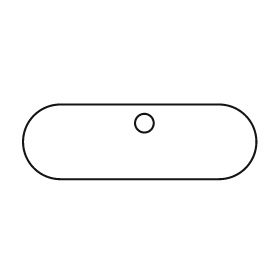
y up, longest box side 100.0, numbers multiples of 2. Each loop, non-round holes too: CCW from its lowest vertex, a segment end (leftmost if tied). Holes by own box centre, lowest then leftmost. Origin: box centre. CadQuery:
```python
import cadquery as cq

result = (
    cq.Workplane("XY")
    .moveTo(-34.0, -16.0)
    .lineTo(34.0, -16.0)
    .threePointArc((50.0, 0.0), (34.0, 16.0))
    .lineTo(-34.0, 16.0)
    .threePointArc((-50.0, 0.0), (-34.0, -16.0))
    .close()
    .moveTo(2.0, 8.0)
    .circle(4.0)
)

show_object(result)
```